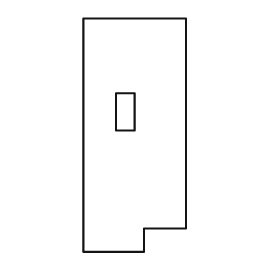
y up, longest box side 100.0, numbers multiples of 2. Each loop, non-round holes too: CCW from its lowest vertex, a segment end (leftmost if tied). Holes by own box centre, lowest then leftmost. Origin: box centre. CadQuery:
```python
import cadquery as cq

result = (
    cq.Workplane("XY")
    .moveTo(-22.0, -50.0)
    .lineTo(4.0, -50.0)
    .lineTo(4.0, -40.0)
    .lineTo(22.0, -40.0)
    .lineTo(22.0, 50.0)
    .lineTo(-22.0, 50.0)
    .close()
    .moveTo(-8.0, 2.0)
    .lineTo(0.0, 2.0)
    .lineTo(0.0, 18.0)
    .lineTo(-8.0, 18.0)
    .close()
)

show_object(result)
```